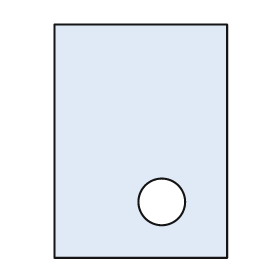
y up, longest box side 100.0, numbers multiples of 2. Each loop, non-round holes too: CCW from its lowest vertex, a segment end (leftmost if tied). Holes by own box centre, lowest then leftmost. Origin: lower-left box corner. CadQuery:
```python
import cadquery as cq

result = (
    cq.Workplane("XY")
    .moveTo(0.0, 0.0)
    .lineTo(74.0, 0.0)
    .lineTo(74.0, 100.0)
    .lineTo(0.0, 100.0)
    .close()
    .moveTo(46.0, 24.0)
    .circle(10.0)
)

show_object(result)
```